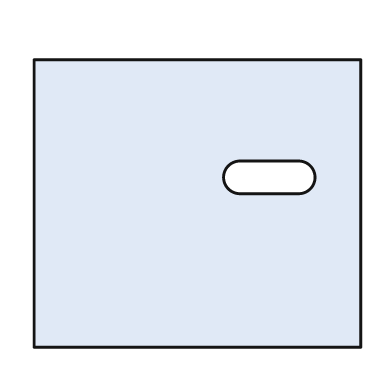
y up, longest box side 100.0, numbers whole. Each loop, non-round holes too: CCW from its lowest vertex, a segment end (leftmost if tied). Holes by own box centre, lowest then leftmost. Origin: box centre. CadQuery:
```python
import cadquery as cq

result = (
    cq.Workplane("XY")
    .moveTo(-50.0, -44.0)
    .lineTo(50.0, -44.0)
    .lineTo(50.0, 44.0)
    .lineTo(-50.0, 44.0)
    .close()
    .moveTo(13.0, 3.0)
    .lineTo(31.0, 3.0)
    .threePointArc((36.0, 8.0), (31.0, 13.0))
    .lineTo(13.0, 13.0)
    .threePointArc((8.0, 8.0), (13.0, 3.0))
    .close()
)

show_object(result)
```